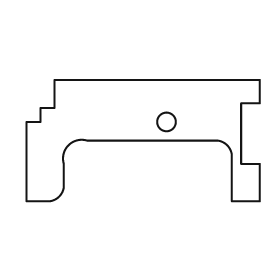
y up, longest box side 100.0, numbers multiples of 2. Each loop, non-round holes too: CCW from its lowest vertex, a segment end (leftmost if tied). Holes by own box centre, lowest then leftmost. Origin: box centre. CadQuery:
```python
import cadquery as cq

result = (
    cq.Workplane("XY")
    .moveTo(-50.0, -26.0)
    .lineTo(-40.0, -26.0)
    .threePointArc((-36.0, -24.0), (-34.0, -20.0))
    .lineTo(-34.0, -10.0)
    .threePointArc((-32.0, -2.0), (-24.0, 0.0))
    .lineTo(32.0, 0.0)
    .threePointArc((36.0, -2.0), (38.0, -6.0))
    .lineTo(38.0, -26.0)
    .lineTo(50.0, -26.0)
    .lineTo(50.0, -10.0)
    .lineTo(42.0, -10.0)
    .lineTo(42.0, 16.0)
    .lineTo(50.0, 16.0)
    .lineTo(50.0, 26.0)
    .lineTo(-38.0, 26.0)
    .lineTo(-38.0, 14.0)
    .lineTo(-44.0, 14.0)
    .lineTo(-44.0, 8.0)
    .lineTo(-50.0, 8.0)
    .close()
    .moveTo(10.0, 8.0)
    .circle(4.0)
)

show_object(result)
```